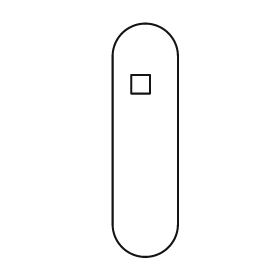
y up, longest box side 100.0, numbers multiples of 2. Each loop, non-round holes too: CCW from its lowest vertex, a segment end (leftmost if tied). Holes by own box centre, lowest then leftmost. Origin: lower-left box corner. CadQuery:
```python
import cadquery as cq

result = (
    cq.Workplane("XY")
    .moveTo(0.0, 14.0)
    .threePointArc((14.0, 0.0), (28.0, 14.0))
    .lineTo(28.0, 86.0)
    .threePointArc((14.0, 100.0), (0.0, 86.0))
    .close()
    .moveTo(8.0, 70.0)
    .lineTo(16.0, 70.0)
    .lineTo(16.0, 78.0)
    .lineTo(8.0, 78.0)
    .close()
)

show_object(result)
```